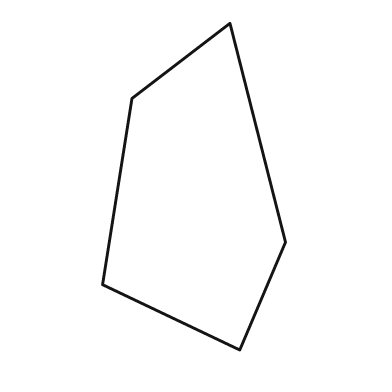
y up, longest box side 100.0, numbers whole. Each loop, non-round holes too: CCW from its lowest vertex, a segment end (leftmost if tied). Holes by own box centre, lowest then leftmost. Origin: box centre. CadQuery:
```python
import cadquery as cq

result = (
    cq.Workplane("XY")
    .moveTo(14.0, -50.0)
    .lineTo(28.0, -17.0)
    .lineTo(11.0, 50.0)
    .lineTo(-19.0, 27.0)
    .lineTo(-28.0, -30.0)
    .close()
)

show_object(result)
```